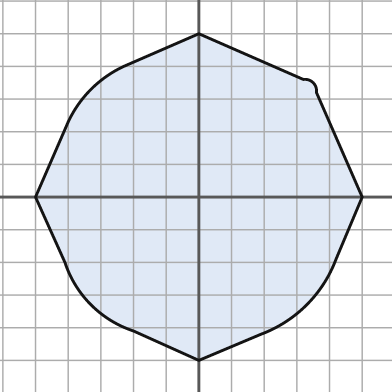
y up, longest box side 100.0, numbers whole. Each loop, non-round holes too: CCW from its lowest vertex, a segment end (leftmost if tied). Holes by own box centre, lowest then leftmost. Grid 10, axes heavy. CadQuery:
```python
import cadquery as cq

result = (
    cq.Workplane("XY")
    .moveTo(0.0, -50.0)
    .lineTo(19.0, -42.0)
    .threePointArc((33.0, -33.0), (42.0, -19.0))
    .lineTo(50.0, 0.0)
    .lineTo(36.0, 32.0)
    .threePointArc((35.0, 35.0), (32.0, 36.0))
    .lineTo(0.0, 50.0)
    .lineTo(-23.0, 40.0)
    .threePointArc((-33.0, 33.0), (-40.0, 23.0))
    .lineTo(-50.0, 0.0)
    .lineTo(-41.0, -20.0)
    .threePointArc((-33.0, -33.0), (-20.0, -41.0))
    .close()
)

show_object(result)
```